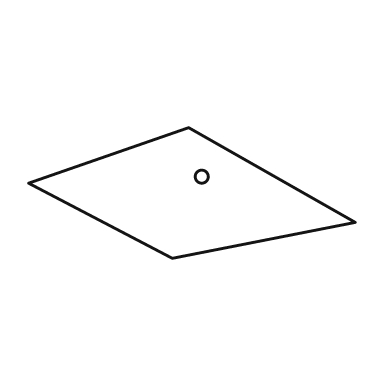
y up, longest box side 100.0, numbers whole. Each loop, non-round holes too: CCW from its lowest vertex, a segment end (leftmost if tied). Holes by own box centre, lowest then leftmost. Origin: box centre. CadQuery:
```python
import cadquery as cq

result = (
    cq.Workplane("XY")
    .moveTo(-6.0, -20.0)
    .lineTo(50.0, -9.0)
    .lineTo(-1.0, 20.0)
    .lineTo(-50.0, 3.0)
    .close()
    .moveTo(3.0, 5.0)
    .circle(2.0)
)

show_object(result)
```